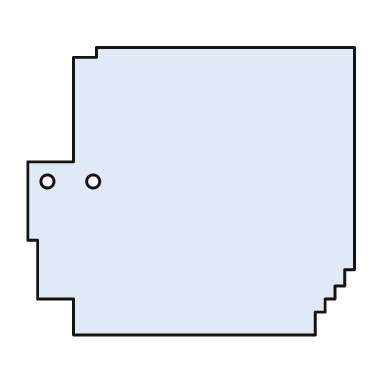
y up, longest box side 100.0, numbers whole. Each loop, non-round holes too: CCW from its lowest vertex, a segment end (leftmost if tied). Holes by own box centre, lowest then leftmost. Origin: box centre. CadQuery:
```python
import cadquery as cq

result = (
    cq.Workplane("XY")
    .moveTo(-36.0, -44.0)
    .lineTo(38.0, -44.0)
    .lineTo(38.0, -37.0)
    .lineTo(41.0, -37.0)
    .lineTo(41.0, -33.0)
    .lineTo(44.0, -33.0)
    .lineTo(44.0, -29.0)
    .lineTo(47.0, -29.0)
    .lineTo(47.0, -24.0)
    .lineTo(50.0, -24.0)
    .lineTo(50.0, 44.0)
    .lineTo(-29.0, 44.0)
    .lineTo(-29.0, 41.0)
    .lineTo(-36.0, 41.0)
    .lineTo(-36.0, 9.0)
    .lineTo(-50.0, 9.0)
    .lineTo(-50.0, -15.0)
    .lineTo(-47.0, -15.0)
    .lineTo(-47.0, -33.0)
    .lineTo(-36.0, -33.0)
    .close()
    .moveTo(-44.0, 3.0)
    .circle(2.0)
    .moveTo(-30.0, 3.0)
    .circle(2.0)
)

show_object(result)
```